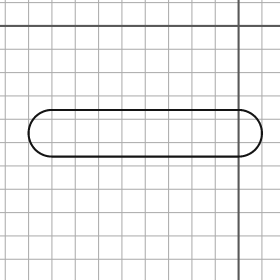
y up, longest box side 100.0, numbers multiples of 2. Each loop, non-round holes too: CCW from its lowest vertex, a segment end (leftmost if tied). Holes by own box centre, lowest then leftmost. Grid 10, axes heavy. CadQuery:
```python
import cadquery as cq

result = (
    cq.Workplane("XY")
    .moveTo(-80.0, -56.0)
    .lineTo(0.0, -56.0)
    .threePointArc((10.0, -46.0), (0.0, -36.0))
    .lineTo(-80.0, -36.0)
    .threePointArc((-90.0, -46.0), (-80.0, -56.0))
    .close()
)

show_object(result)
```